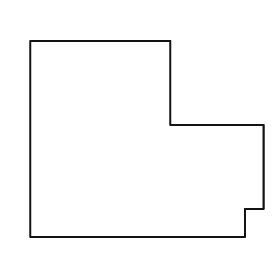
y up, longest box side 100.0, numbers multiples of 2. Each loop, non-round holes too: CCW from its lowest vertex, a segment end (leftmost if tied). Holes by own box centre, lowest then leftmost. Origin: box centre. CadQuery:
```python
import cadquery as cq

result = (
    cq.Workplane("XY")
    .moveTo(-50.0, -42.0)
    .lineTo(42.0, -42.0)
    .lineTo(42.0, -30.0)
    .lineTo(50.0, -30.0)
    .lineTo(50.0, 6.0)
    .lineTo(10.0, 6.0)
    .lineTo(10.0, 42.0)
    .lineTo(-50.0, 42.0)
    .close()
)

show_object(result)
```